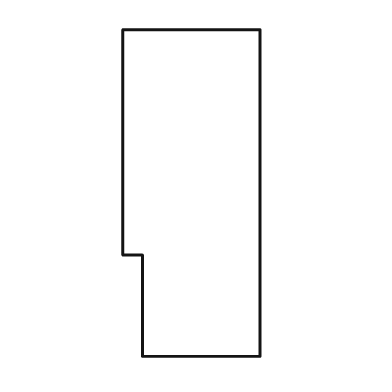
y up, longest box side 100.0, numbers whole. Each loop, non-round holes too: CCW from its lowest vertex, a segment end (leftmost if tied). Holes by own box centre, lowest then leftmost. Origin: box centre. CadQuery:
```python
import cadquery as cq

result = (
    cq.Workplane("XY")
    .moveTo(-15.0, -50.0)
    .lineTo(21.0, -50.0)
    .lineTo(21.0, 50.0)
    .lineTo(-21.0, 50.0)
    .lineTo(-21.0, -19.0)
    .lineTo(-15.0, -19.0)
    .close()
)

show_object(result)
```